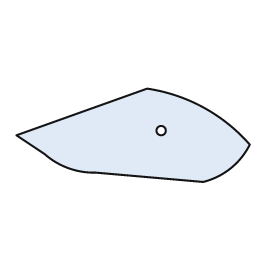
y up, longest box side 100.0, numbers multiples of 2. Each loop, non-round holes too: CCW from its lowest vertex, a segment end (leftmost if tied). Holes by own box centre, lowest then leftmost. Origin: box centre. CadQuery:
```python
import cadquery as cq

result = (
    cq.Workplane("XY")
    .moveTo(30.0, -20.0)
    .threePointArc((42.0, -14.0), (50.0, -4.0))
    .threePointArc((30.0, 12.0), (6.0, 20.0))
    .lineTo(-50.0, 0.0)
    .lineTo(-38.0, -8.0)
    .threePointArc((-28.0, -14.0), (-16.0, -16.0))
    .close()
    .moveTo(12.0, 2.0)
    .circle(2.0)
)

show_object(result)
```